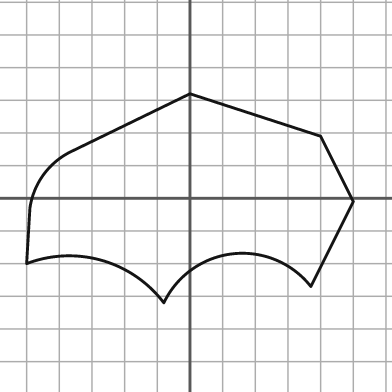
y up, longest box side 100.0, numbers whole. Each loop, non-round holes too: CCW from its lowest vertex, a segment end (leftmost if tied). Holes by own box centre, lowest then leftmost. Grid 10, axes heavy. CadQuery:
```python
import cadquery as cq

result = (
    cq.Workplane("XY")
    .moveTo(-8.0, -32.0)
    .threePointArc((13.0, -17.0), (37.0, -27.0))
    .lineTo(50.0, -1.0)
    .lineTo(40.0, 19.0)
    .lineTo(0.0, 32.0)
    .lineTo(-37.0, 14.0)
    .threePointArc((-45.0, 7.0), (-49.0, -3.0))
    .lineTo(-50.0, -20.0)
    .threePointArc((-27.0, -19.0), (-8.0, -32.0))
    .close()
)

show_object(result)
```